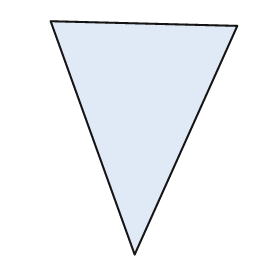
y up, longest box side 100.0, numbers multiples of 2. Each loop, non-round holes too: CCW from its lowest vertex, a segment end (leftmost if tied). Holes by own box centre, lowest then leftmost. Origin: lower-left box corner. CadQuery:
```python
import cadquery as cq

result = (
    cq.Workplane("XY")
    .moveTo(36.0, 0.0)
    .lineTo(80.0, 98.0)
    .lineTo(0.0, 100.0)
    .close()
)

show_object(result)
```